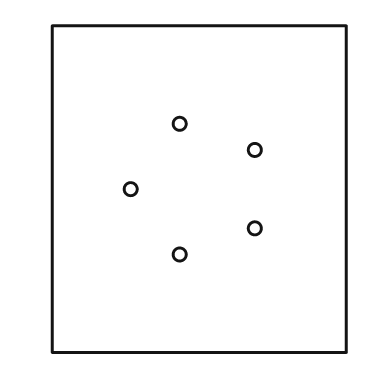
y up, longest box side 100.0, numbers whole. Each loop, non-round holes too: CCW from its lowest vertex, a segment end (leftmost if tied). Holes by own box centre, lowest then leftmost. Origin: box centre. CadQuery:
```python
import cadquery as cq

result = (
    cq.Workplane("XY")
    .moveTo(-45.0, -50.0)
    .lineTo(45.0, -50.0)
    .lineTo(45.0, 50.0)
    .lineTo(-45.0, 50.0)
    .close()
    .moveTo(-6.0, -20.0)
    .circle(2.0)
    .moveTo(17.0, -12.0)
    .circle(2.0)
    .moveTo(-21.0, 0.0)
    .circle(2.0)
    .moveTo(17.0, 12.0)
    .circle(2.0)
    .moveTo(-6.0, 20.0)
    .circle(2.0)
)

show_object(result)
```